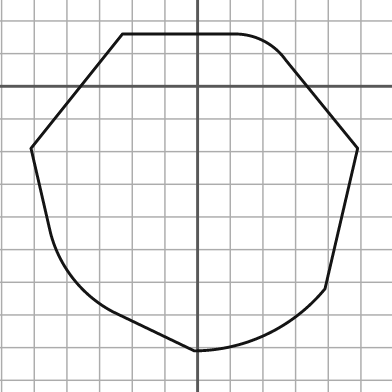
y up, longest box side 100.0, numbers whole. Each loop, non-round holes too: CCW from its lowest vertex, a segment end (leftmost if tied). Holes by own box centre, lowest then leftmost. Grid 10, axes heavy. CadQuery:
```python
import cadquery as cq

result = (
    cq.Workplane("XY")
    .moveTo(-1.0, -81.0)
    .threePointArc((21.0, -76.0), (39.0, -62.0))
    .lineTo(49.0, -19.0)
    .lineTo(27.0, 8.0)
    .threePointArc((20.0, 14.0), (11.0, 16.0))
    .lineTo(-23.0, 16.0)
    .lineTo(-51.0, -19.0)
    .lineTo(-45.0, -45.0)
    .threePointArc((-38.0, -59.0), (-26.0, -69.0))
    .close()
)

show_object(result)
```